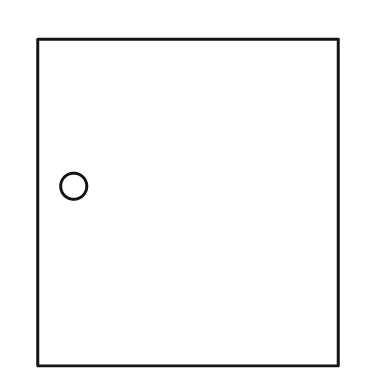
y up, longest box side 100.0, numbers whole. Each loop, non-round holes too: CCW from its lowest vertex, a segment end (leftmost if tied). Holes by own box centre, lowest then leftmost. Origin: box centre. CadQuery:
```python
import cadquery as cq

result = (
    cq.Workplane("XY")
    .moveTo(-46.0, -50.0)
    .lineTo(46.0, -50.0)
    .lineTo(46.0, 50.0)
    .lineTo(-46.0, 50.0)
    .close()
    .moveTo(-35.0, 5.0)
    .circle(4.0)
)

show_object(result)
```